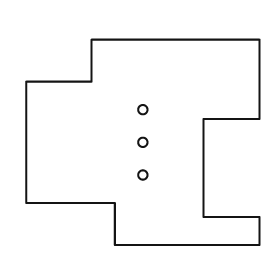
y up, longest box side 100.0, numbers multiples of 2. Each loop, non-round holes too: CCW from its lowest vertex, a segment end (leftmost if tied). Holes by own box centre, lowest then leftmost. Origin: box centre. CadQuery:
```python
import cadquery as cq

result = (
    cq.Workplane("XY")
    .moveTo(-12.0, -44.0)
    .lineTo(50.0, -44.0)
    .lineTo(50.0, -32.0)
    .lineTo(26.0, -32.0)
    .lineTo(26.0, 10.0)
    .lineTo(50.0, 10.0)
    .lineTo(50.0, 44.0)
    .lineTo(-22.0, 44.0)
    .lineTo(-22.0, 26.0)
    .lineTo(-50.0, 26.0)
    .lineTo(-50.0, -26.0)
    .lineTo(-12.0, -26.0)
    .close()
    .moveTo(0.0, -14.0)
    .circle(2.0)
    .moveTo(0.0, 0.0)
    .circle(2.0)
    .moveTo(0.0, 14.0)
    .circle(2.0)
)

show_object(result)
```